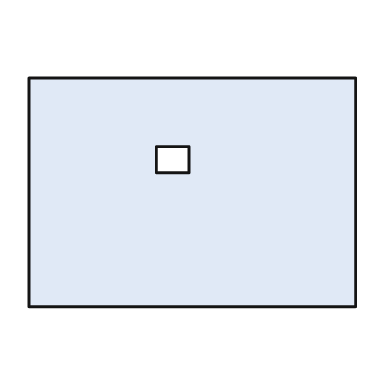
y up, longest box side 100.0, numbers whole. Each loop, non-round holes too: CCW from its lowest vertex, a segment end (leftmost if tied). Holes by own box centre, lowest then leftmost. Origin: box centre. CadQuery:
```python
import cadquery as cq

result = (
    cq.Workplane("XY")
    .moveTo(-50.0, -35.0)
    .lineTo(50.0, -35.0)
    .lineTo(50.0, 35.0)
    .lineTo(-50.0, 35.0)
    .close()
    .moveTo(-11.0, 6.0)
    .lineTo(-1.0, 6.0)
    .lineTo(-1.0, 14.0)
    .lineTo(-11.0, 14.0)
    .close()
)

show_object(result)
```